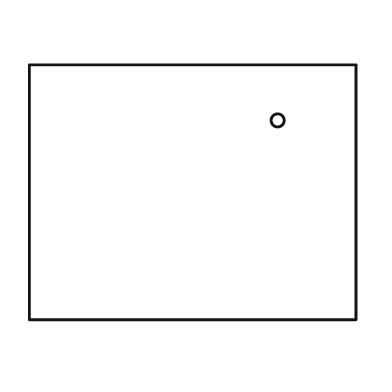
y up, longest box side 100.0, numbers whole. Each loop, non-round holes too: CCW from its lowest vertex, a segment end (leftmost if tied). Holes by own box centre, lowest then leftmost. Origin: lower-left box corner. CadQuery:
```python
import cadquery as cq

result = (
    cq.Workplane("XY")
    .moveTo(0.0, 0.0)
    .lineTo(100.0, 0.0)
    .lineTo(100.0, 78.0)
    .lineTo(0.0, 78.0)
    .close()
    .moveTo(76.0, 61.0)
    .circle(2.0)
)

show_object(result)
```